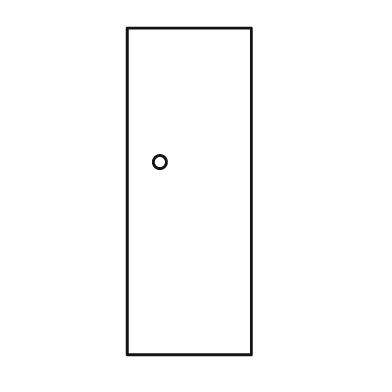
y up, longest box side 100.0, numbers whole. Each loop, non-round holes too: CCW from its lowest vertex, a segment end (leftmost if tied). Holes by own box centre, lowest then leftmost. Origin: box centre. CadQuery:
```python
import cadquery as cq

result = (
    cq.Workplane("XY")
    .moveTo(-19.0, -50.0)
    .lineTo(19.0, -50.0)
    .lineTo(19.0, 50.0)
    .lineTo(-19.0, 50.0)
    .close()
    .moveTo(-9.0, 9.0)
    .circle(2.0)
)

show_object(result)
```